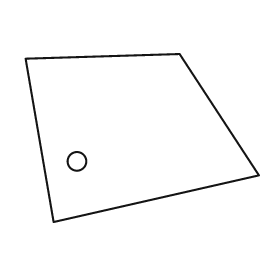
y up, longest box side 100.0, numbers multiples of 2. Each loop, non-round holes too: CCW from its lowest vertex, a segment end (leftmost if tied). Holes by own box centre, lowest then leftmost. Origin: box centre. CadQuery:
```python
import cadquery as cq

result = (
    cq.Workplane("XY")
    .moveTo(-38.0, -36.0)
    .lineTo(50.0, -16.0)
    .lineTo(16.0, 36.0)
    .lineTo(-50.0, 34.0)
    .close()
    .moveTo(-28.0, -10.0)
    .circle(4.0)
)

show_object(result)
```